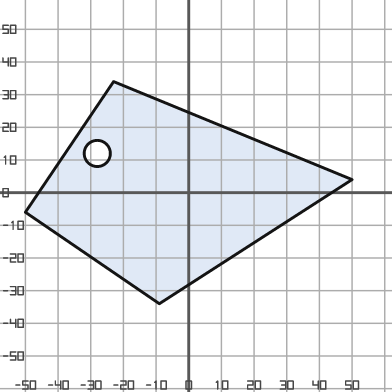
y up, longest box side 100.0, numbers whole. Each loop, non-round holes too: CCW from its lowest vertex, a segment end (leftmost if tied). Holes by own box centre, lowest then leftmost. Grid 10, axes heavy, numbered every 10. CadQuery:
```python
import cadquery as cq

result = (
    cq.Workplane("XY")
    .moveTo(-9.0, -34.0)
    .lineTo(50.0, 4.0)
    .lineTo(-23.0, 34.0)
    .lineTo(-50.0, -6.0)
    .close()
    .moveTo(-28.0, 12.0)
    .circle(4.0)
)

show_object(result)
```